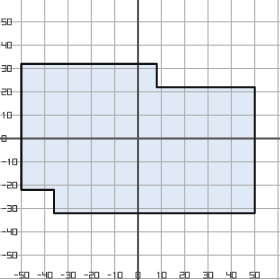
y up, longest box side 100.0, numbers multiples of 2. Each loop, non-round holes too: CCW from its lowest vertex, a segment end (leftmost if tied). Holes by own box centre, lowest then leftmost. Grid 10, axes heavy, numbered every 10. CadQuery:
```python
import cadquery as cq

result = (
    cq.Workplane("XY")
    .moveTo(-36.0, -32.0)
    .lineTo(50.0, -32.0)
    .lineTo(50.0, 22.0)
    .lineTo(8.0, 22.0)
    .lineTo(8.0, 32.0)
    .lineTo(-50.0, 32.0)
    .lineTo(-50.0, -22.0)
    .lineTo(-36.0, -22.0)
    .close()
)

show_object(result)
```